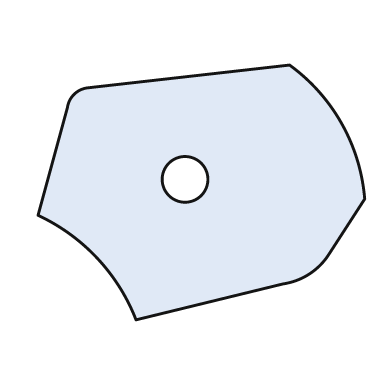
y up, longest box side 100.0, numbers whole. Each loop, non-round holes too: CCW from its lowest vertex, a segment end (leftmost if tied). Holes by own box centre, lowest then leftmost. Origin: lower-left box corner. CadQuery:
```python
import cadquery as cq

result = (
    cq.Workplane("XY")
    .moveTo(30.0, 0.0)
    .lineTo(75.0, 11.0)
    .threePointArc((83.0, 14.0), (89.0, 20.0))
    .lineTo(100.0, 37.0)
    .threePointArc((93.0, 60.0), (77.0, 78.0))
    .lineTo(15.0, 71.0)
    .threePointArc((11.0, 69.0), (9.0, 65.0))
    .lineTo(0.0, 32.0)
    .threePointArc((18.0, 19.0), (30.0, 0.0))
    .close()
    .moveTo(45.0, 43.0)
    .circle(7.0)
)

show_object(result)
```